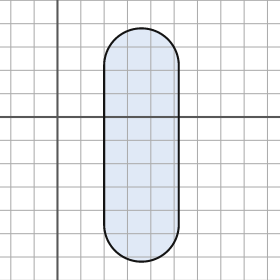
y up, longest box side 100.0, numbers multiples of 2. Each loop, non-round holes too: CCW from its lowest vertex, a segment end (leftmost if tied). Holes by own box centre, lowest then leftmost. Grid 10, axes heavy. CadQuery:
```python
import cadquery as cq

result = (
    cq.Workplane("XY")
    .moveTo(20.0, -46.0)
    .threePointArc((36.0, -62.0), (52.0, -46.0))
    .lineTo(52.0, 22.0)
    .threePointArc((36.0, 38.0), (20.0, 22.0))
    .close()
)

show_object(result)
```